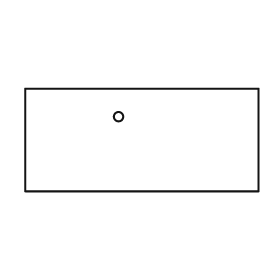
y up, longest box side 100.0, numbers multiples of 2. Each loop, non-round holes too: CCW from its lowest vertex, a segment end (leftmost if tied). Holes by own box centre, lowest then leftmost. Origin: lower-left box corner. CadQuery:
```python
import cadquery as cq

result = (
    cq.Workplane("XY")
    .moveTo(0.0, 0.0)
    .lineTo(100.0, 0.0)
    .lineTo(100.0, 44.0)
    .lineTo(0.0, 44.0)
    .close()
    .moveTo(40.0, 32.0)
    .circle(2.0)
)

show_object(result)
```